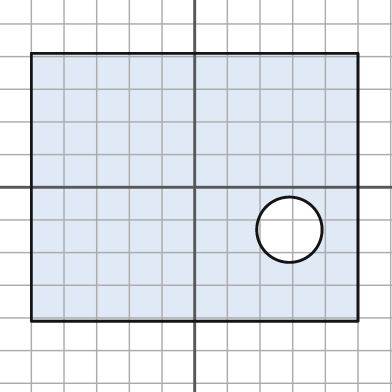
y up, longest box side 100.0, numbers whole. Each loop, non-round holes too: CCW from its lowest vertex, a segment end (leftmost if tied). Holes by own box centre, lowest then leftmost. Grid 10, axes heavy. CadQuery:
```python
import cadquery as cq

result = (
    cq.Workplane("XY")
    .moveTo(-50.0, -41.0)
    .lineTo(50.0, -41.0)
    .lineTo(50.0, 41.0)
    .lineTo(-50.0, 41.0)
    .close()
    .moveTo(29.0, -13.0)
    .circle(10.0)
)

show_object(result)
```